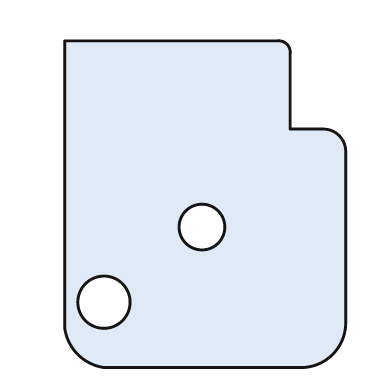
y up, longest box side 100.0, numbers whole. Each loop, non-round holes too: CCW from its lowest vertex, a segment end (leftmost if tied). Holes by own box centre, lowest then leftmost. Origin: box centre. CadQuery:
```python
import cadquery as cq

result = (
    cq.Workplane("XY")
    .moveTo(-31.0, -50.0)
    .lineTo(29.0, -50.0)
    .threePointArc((39.0, -46.0), (43.0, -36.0))
    .lineTo(43.0, 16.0)
    .threePointArc((41.0, 21.0), (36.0, 23.0))
    .lineTo(26.0, 23.0)
    .lineTo(26.0, 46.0)
    .threePointArc((25.0, 49.0), (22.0, 50.0))
    .lineTo(-43.0, 50.0)
    .lineTo(-43.0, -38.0)
    .threePointArc((-39.0, -46.0), (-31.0, -50.0))
    .close()
    .moveTo(-31.0, -30.0)
    .circle(8.0)
    .moveTo(-1.0, -7.0)
    .circle(7.0)
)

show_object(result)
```